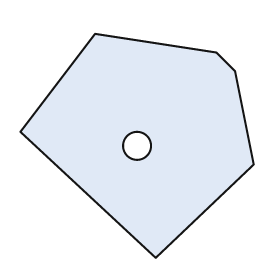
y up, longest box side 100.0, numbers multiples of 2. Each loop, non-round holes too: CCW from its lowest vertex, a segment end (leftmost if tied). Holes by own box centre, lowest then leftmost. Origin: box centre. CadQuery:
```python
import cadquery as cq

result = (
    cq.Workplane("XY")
    .moveTo(8.0, -48.0)
    .lineTo(50.0, -8.0)
    .lineTo(42.0, 32.0)
    .lineTo(34.0, 40.0)
    .lineTo(-18.0, 48.0)
    .lineTo(-50.0, 6.0)
    .close()
    .moveTo(0.0, 0.0)
    .circle(6.0)
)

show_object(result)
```